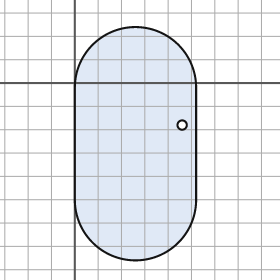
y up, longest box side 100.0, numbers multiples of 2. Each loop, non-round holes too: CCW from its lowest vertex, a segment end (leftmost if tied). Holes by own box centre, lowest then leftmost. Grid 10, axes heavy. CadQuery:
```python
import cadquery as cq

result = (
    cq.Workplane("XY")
    .moveTo(0.0, -50.0)
    .threePointArc((26.0, -76.0), (52.0, -50.0))
    .lineTo(52.0, -2.0)
    .threePointArc((26.0, 24.0), (0.0, -2.0))
    .close()
    .moveTo(46.0, -18.0)
    .circle(2.0)
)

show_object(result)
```